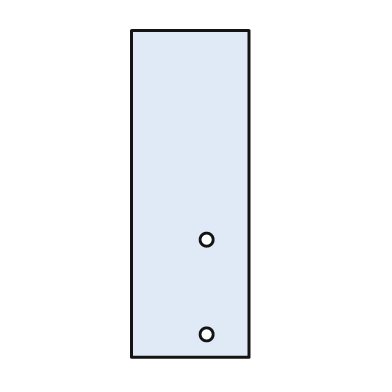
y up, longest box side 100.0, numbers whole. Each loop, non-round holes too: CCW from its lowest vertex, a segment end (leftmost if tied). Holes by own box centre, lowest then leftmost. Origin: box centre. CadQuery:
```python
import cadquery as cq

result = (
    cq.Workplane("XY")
    .moveTo(-18.0, -50.0)
    .lineTo(18.0, -50.0)
    .lineTo(18.0, 50.0)
    .lineTo(-18.0, 50.0)
    .close()
    .moveTo(5.0, -43.0)
    .circle(2.0)
    .moveTo(5.0, -14.0)
    .circle(2.0)
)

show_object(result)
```